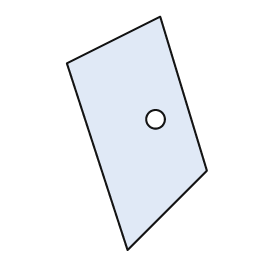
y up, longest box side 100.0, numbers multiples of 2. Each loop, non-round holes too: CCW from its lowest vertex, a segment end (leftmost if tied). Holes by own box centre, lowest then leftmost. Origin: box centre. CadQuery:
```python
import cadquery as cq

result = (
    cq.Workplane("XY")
    .moveTo(-4.0, -50.0)
    .lineTo(30.0, -16.0)
    .lineTo(10.0, 50.0)
    .lineTo(-30.0, 30.0)
    .close()
    .moveTo(8.0, 6.0)
    .circle(4.0)
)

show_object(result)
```